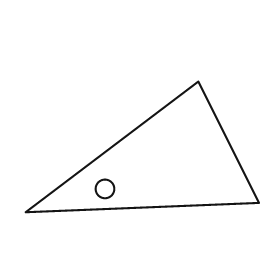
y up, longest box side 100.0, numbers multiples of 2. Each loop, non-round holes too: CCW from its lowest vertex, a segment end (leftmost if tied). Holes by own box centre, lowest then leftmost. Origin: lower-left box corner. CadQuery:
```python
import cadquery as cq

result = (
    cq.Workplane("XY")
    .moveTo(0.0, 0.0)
    .lineTo(100.0, 4.0)
    .lineTo(74.0, 56.0)
    .close()
    .moveTo(34.0, 10.0)
    .circle(4.0)
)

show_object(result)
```